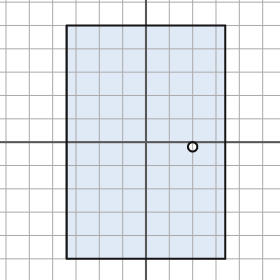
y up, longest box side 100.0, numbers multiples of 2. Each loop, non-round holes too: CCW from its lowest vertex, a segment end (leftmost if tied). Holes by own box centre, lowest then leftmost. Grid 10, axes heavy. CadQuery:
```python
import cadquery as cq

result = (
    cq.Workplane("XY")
    .moveTo(-34.0, -50.0)
    .lineTo(34.0, -50.0)
    .lineTo(34.0, 50.0)
    .lineTo(-34.0, 50.0)
    .close()
    .moveTo(20.0, -2.0)
    .circle(2.0)
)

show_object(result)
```